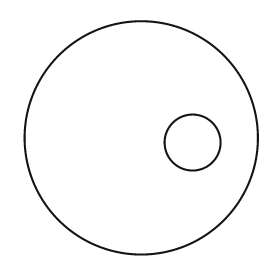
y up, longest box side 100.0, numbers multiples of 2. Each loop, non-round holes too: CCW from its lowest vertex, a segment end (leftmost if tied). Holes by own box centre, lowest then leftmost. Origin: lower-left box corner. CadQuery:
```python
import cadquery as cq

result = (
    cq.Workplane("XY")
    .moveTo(50.0, 50.0)
    .circle(50.0)
    .moveTo(72.0, 48.0)
    .circle(12.0)
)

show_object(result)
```